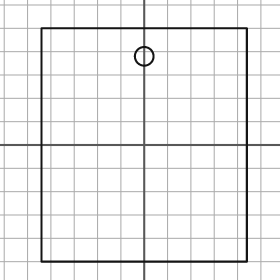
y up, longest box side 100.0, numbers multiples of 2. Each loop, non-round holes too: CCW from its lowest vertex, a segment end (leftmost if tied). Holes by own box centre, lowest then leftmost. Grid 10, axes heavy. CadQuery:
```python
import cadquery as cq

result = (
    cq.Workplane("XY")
    .moveTo(-44.0, -50.0)
    .lineTo(44.0, -50.0)
    .lineTo(44.0, 50.0)
    .lineTo(-44.0, 50.0)
    .close()
    .moveTo(0.0, 38.0)
    .circle(4.0)
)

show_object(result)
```